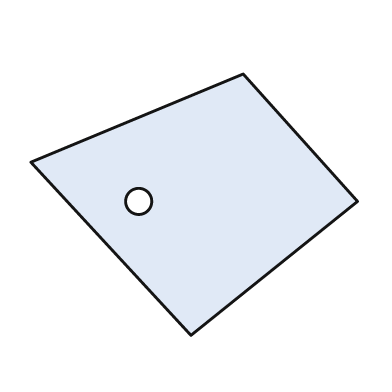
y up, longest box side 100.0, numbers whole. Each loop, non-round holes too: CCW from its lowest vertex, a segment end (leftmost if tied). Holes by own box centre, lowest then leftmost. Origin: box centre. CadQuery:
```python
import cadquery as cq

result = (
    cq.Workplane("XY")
    .moveTo(-1.0, -40.0)
    .lineTo(50.0, 1.0)
    .lineTo(15.0, 40.0)
    .lineTo(-50.0, 13.0)
    .close()
    .moveTo(-17.0, 1.0)
    .circle(4.0)
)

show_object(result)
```